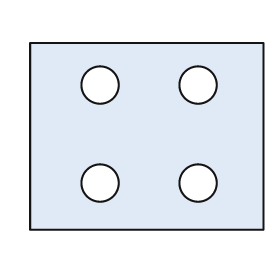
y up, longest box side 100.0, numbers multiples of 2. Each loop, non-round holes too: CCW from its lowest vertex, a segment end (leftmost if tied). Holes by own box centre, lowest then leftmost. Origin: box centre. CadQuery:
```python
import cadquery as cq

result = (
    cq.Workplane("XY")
    .moveTo(-50.0, -40.0)
    .lineTo(50.0, -40.0)
    .lineTo(50.0, 40.0)
    .lineTo(-50.0, 40.0)
    .close()
    .moveTo(-20.0, -20.0)
    .circle(8.0)
    .moveTo(22.0, -20.0)
    .circle(8.0)
    .moveTo(-20.0, 22.0)
    .circle(8.0)
    .moveTo(22.0, 22.0)
    .circle(8.0)
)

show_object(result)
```